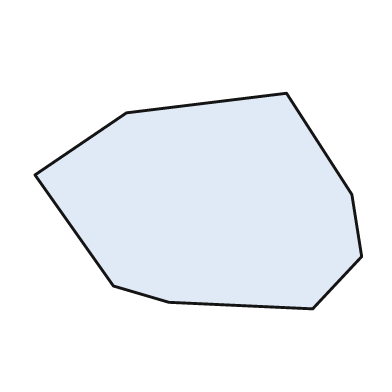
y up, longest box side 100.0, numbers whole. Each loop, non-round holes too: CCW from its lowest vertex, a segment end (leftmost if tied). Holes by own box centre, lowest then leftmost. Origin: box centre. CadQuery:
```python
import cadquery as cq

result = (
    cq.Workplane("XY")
    .moveTo(35.0, -33.0)
    .lineTo(50.0, -17.0)
    .lineTo(47.0, 2.0)
    .lineTo(27.0, 33.0)
    .lineTo(-22.0, 27.0)
    .lineTo(-50.0, 8.0)
    .lineTo(-26.0, -26.0)
    .lineTo(-9.0, -31.0)
    .close()
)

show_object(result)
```